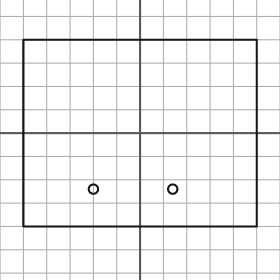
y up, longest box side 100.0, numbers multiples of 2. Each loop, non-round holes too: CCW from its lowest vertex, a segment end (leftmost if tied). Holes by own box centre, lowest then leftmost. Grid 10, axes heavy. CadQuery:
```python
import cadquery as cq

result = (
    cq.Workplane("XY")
    .moveTo(-50.0, -40.0)
    .lineTo(50.0, -40.0)
    .lineTo(50.0, 40.0)
    .lineTo(-50.0, 40.0)
    .close()
    .moveTo(-20.0, -24.0)
    .circle(2.0)
    .moveTo(14.0, -24.0)
    .circle(2.0)
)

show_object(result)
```